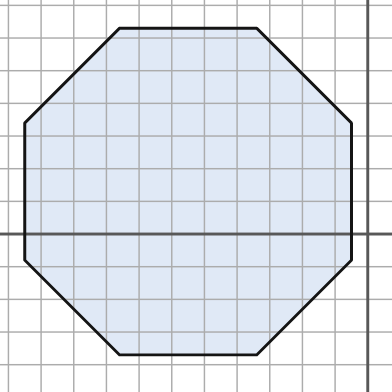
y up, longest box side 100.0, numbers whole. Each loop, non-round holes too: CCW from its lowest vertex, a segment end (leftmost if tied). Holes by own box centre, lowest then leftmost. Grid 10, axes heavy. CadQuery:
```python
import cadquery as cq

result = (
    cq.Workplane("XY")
    .moveTo(-76.0, -37.0)
    .lineTo(-34.0, -37.0)
    .lineTo(-5.0, -8.0)
    .lineTo(-5.0, 34.0)
    .lineTo(-34.0, 63.0)
    .lineTo(-76.0, 63.0)
    .lineTo(-105.0, 34.0)
    .lineTo(-105.0, -8.0)
    .close()
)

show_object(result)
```